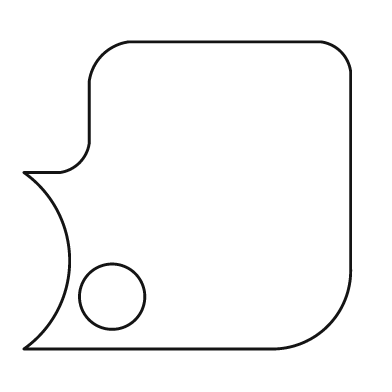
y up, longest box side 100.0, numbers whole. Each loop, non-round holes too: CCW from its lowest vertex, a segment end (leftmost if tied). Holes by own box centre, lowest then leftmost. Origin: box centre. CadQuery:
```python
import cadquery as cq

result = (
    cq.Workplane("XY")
    .moveTo(-50.0, -47.0)
    .lineTo(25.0, -47.0)
    .threePointArc((43.0, -40.0), (50.0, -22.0))
    .lineTo(50.0, 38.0)
    .threePointArc((47.0, 44.0), (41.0, 47.0))
    .lineTo(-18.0, 47.0)
    .threePointArc((-26.0, 43.0), (-30.0, 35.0))
    .lineTo(-30.0, 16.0)
    .threePointArc((-33.0, 10.0), (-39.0, 7.0))
    .lineTo(-50.0, 7.0)
    .threePointArc((-36.0, -20.0), (-50.0, -47.0))
    .close()
    .moveTo(-23.0, -31.0)
    .circle(10.0)
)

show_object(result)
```